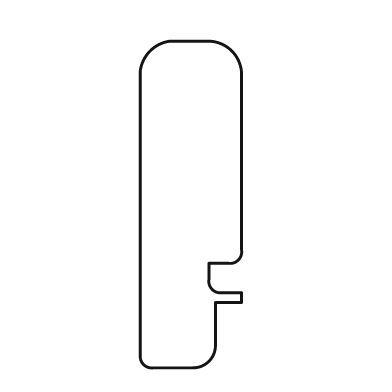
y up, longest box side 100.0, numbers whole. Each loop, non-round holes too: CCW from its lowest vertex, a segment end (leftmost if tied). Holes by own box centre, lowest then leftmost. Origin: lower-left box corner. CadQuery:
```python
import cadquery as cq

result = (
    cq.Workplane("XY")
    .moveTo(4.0, 0.0)
    .lineTo(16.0, 0.0)
    .threePointArc((21.0, 2.0), (23.0, 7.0))
    .lineTo(23.0, 20.0)
    .lineTo(31.0, 20.0)
    .lineTo(31.0, 23.0)
    .lineTo(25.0, 23.0)
    .threePointArc((22.0, 24.0), (21.0, 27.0))
    .lineTo(21.0, 32.0)
    .lineTo(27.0, 32.0)
    .threePointArc((30.0, 33.0), (31.0, 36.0))
    .lineTo(31.0, 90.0)
    .threePointArc((28.0, 97.0), (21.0, 100.0))
    .lineTo(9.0, 100.0)
    .threePointArc((3.0, 97.0), (0.0, 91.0))
    .lineTo(0.0, 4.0)
    .threePointArc((1.0, 1.0), (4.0, 0.0))
    .close()
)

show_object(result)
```